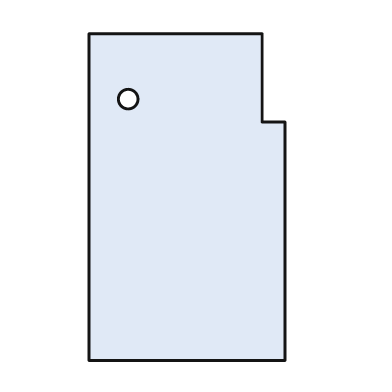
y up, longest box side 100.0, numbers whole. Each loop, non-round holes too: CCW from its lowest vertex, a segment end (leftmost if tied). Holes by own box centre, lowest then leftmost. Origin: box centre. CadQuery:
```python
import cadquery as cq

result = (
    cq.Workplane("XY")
    .moveTo(-30.0, -50.0)
    .lineTo(30.0, -50.0)
    .lineTo(30.0, 23.0)
    .lineTo(23.0, 23.0)
    .lineTo(23.0, 50.0)
    .lineTo(-30.0, 50.0)
    .close()
    .moveTo(-18.0, 30.0)
    .circle(3.0)
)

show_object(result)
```